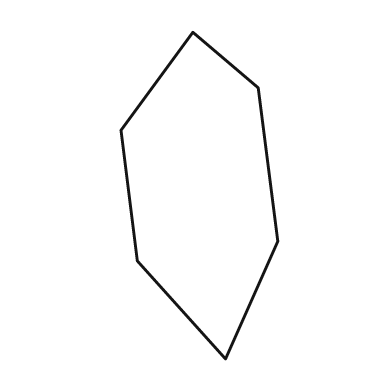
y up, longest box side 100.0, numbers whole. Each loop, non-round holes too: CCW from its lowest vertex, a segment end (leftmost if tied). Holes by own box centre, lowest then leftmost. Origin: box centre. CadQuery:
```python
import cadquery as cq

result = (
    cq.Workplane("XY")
    .moveTo(8.0, -50.0)
    .lineTo(24.0, -14.0)
    .lineTo(18.0, 33.0)
    .lineTo(-2.0, 50.0)
    .lineTo(-24.0, 20.0)
    .lineTo(-19.0, -20.0)
    .close()
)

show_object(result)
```